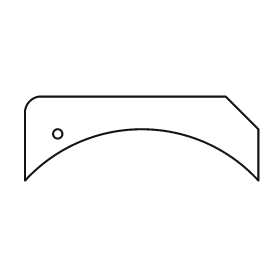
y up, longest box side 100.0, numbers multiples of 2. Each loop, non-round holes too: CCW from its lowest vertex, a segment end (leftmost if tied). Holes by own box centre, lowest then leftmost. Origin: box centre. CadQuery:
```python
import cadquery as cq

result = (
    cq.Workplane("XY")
    .moveTo(-50.0, -18.0)
    .threePointArc((0.0, 4.0), (50.0, -18.0))
    .lineTo(50.0, 4.0)
    .lineTo(36.0, 18.0)
    .lineTo(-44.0, 18.0)
    .threePointArc((-48.0, 16.0), (-50.0, 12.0))
    .close()
    .moveTo(-36.0, 2.0)
    .circle(2.0)
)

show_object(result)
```